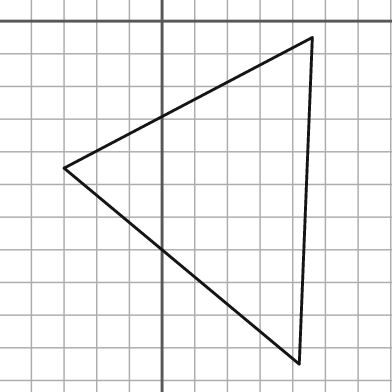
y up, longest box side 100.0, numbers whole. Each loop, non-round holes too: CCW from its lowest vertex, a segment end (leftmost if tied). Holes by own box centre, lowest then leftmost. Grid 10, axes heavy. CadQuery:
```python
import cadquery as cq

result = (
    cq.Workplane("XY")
    .moveTo(42.0, -105.0)
    .lineTo(46.0, -5.0)
    .lineTo(-30.0, -45.0)
    .close()
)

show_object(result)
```